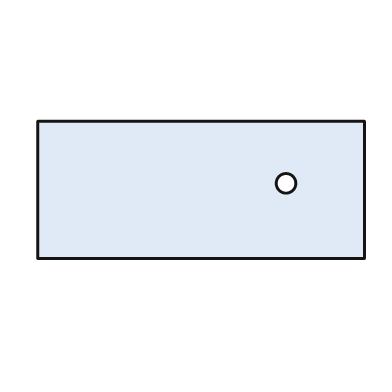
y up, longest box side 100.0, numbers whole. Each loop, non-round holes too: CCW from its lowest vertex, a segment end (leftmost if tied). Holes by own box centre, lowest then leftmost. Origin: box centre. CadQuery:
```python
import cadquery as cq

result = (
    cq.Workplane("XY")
    .moveTo(-50.0, -21.0)
    .lineTo(50.0, -21.0)
    .lineTo(50.0, 21.0)
    .lineTo(-50.0, 21.0)
    .close()
    .moveTo(26.0, 2.0)
    .circle(3.0)
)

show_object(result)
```